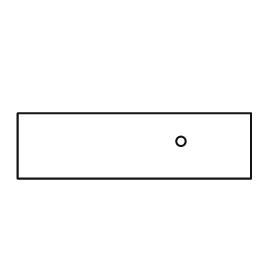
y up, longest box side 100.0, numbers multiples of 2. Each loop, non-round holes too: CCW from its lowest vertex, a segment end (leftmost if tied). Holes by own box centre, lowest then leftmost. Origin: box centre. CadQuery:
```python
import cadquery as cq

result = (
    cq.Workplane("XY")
    .moveTo(-50.0, -14.0)
    .lineTo(50.0, -14.0)
    .lineTo(50.0, 14.0)
    .lineTo(-50.0, 14.0)
    .close()
    .moveTo(20.0, 2.0)
    .circle(2.0)
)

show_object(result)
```